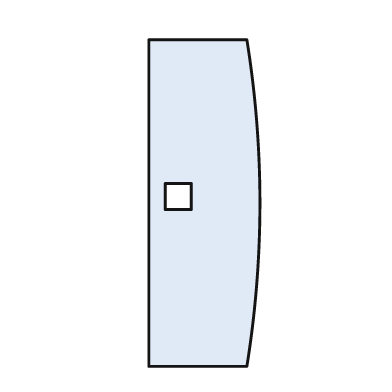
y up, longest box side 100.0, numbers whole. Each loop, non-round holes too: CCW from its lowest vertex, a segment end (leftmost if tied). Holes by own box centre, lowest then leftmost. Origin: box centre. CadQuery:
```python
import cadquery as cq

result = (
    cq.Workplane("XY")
    .moveTo(-17.0, -50.0)
    .lineTo(13.0, -50.0)
    .threePointArc((17.0, 0.0), (13.0, 50.0))
    .lineTo(-17.0, 50.0)
    .close()
    .moveTo(-12.0, -2.0)
    .lineTo(-4.0, -2.0)
    .lineTo(-4.0, 6.0)
    .lineTo(-12.0, 6.0)
    .close()
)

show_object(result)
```